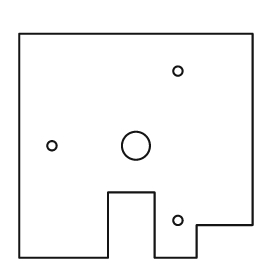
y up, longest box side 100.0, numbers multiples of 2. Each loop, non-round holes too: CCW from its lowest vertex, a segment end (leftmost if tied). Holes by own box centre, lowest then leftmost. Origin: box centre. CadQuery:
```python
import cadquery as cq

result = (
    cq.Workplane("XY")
    .moveTo(-50.0, -48.0)
    .lineTo(-12.0, -48.0)
    .lineTo(-12.0, -20.0)
    .lineTo(8.0, -20.0)
    .lineTo(8.0, -48.0)
    .lineTo(26.0, -48.0)
    .lineTo(26.0, -34.0)
    .lineTo(50.0, -34.0)
    .lineTo(50.0, 48.0)
    .lineTo(-50.0, 48.0)
    .close()
    .moveTo(18.0, -32.0)
    .circle(2.0)
    .moveTo(-36.0, 0.0)
    .circle(2.0)
    .moveTo(0.0, 0.0)
    .circle(6.0)
    .moveTo(18.0, 32.0)
    .circle(2.0)
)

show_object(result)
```